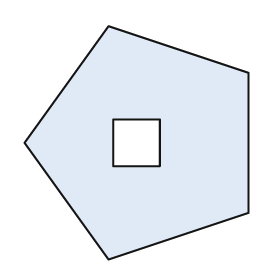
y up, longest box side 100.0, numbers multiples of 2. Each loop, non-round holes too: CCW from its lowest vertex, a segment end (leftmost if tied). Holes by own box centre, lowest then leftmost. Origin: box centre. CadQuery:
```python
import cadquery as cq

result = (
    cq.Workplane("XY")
    .moveTo(-12.0, -50.0)
    .lineTo(48.0, -30.0)
    .lineTo(48.0, 30.0)
    .lineTo(-12.0, 50.0)
    .lineTo(-48.0, 0.0)
    .close()
    .moveTo(-10.0, -10.0)
    .lineTo(10.0, -10.0)
    .lineTo(10.0, 10.0)
    .lineTo(-10.0, 10.0)
    .close()
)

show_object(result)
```